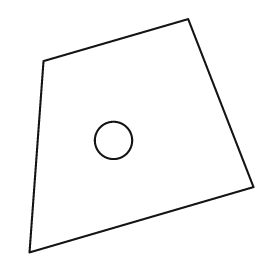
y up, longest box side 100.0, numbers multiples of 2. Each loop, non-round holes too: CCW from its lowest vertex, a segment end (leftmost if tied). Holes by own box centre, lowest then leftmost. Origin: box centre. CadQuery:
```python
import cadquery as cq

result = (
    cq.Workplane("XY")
    .moveTo(-48.0, -50.0)
    .lineTo(48.0, -22.0)
    .lineTo(20.0, 50.0)
    .lineTo(-42.0, 32.0)
    .close()
    .moveTo(-12.0, -2.0)
    .circle(8.0)
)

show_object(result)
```